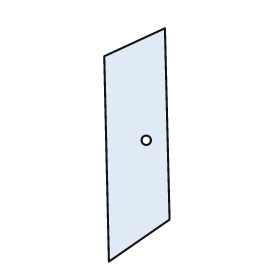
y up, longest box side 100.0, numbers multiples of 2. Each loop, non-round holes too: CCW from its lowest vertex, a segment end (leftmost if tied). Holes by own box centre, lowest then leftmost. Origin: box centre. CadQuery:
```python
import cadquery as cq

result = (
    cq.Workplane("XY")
    .moveTo(-12.0, -50.0)
    .lineTo(14.0, -32.0)
    .lineTo(12.0, 50.0)
    .lineTo(-14.0, 38.0)
    .close()
    .moveTo(4.0, 2.0)
    .circle(2.0)
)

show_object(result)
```